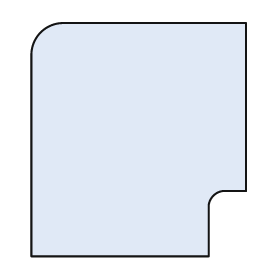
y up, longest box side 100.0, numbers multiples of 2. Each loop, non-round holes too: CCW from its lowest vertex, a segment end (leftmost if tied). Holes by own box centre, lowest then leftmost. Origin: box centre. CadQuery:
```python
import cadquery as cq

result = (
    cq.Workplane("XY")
    .moveTo(-46.0, -50.0)
    .lineTo(30.0, -50.0)
    .lineTo(30.0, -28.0)
    .threePointArc((32.0, -24.0), (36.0, -22.0))
    .lineTo(46.0, -22.0)
    .lineTo(46.0, 50.0)
    .lineTo(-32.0, 50.0)
    .threePointArc((-42.0, 46.0), (-46.0, 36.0))
    .close()
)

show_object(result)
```